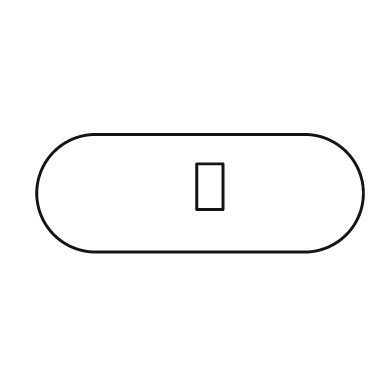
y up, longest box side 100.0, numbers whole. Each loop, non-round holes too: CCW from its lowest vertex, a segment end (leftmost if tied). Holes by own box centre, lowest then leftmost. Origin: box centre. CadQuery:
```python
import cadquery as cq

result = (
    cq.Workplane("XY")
    .moveTo(-32.0, -18.0)
    .lineTo(32.0, -18.0)
    .threePointArc((50.0, 0.0), (32.0, 18.0))
    .lineTo(-32.0, 18.0)
    .threePointArc((-50.0, 0.0), (-32.0, -18.0))
    .close()
    .moveTo(-1.0, -5.0)
    .lineTo(7.0, -5.0)
    .lineTo(7.0, 9.0)
    .lineTo(-1.0, 9.0)
    .close()
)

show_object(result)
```